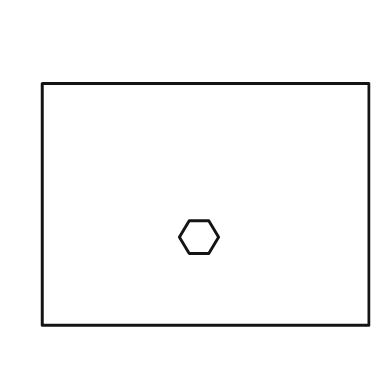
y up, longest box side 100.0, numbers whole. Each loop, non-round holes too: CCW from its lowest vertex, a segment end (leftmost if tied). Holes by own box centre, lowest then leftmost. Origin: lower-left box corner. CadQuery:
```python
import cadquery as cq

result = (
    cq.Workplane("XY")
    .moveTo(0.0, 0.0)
    .lineTo(100.0, 0.0)
    .lineTo(100.0, 74.0)
    .lineTo(0.0, 74.0)
    .close()
    .moveTo(45.0, 22.0)
    .lineTo(51.0, 22.0)
    .lineTo(54.0, 27.0)
    .lineTo(51.0, 32.0)
    .lineTo(45.0, 32.0)
    .lineTo(42.0, 27.0)
    .close()
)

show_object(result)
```